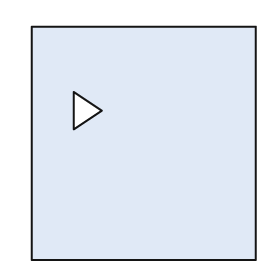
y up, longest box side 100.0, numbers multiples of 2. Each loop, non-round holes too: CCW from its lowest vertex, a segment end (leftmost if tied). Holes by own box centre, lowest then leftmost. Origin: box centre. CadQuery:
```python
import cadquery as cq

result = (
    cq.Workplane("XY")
    .moveTo(-48.0, -50.0)
    .lineTo(48.0, -50.0)
    .lineTo(48.0, 50.0)
    .lineTo(-48.0, 50.0)
    .close()
    .moveTo(-30.0, 6.0)
    .lineTo(-18.0, 14.0)
    .lineTo(-30.0, 22.0)
    .close()
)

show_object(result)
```